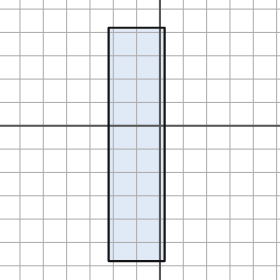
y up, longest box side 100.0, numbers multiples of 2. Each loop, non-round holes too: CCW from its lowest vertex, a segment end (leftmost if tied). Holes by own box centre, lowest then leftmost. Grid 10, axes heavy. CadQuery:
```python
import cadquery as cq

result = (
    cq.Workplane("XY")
    .moveTo(-22.0, -58.0)
    .lineTo(2.0, -58.0)
    .lineTo(2.0, 42.0)
    .lineTo(-22.0, 42.0)
    .close()
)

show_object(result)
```